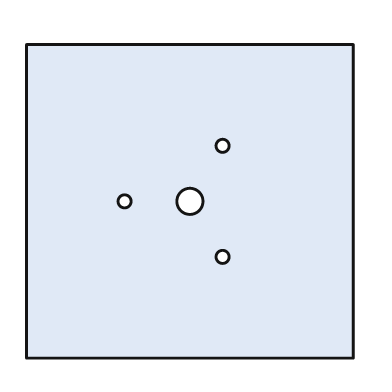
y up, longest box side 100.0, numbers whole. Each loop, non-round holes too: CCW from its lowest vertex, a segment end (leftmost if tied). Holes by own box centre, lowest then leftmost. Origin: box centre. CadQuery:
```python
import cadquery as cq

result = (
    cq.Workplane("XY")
    .moveTo(-50.0, -48.0)
    .lineTo(50.0, -48.0)
    .lineTo(50.0, 48.0)
    .lineTo(-50.0, 48.0)
    .close()
    .moveTo(10.0, -17.0)
    .circle(2.0)
    .moveTo(-20.0, 0.0)
    .circle(2.0)
    .moveTo(0.0, 0.0)
    .circle(4.0)
    .moveTo(10.0, 17.0)
    .circle(2.0)
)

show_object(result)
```